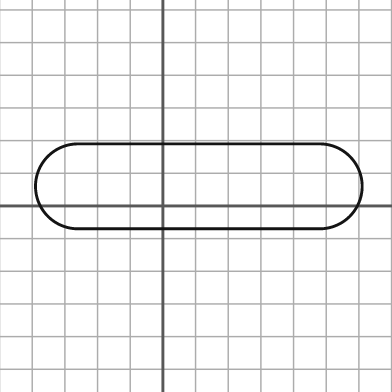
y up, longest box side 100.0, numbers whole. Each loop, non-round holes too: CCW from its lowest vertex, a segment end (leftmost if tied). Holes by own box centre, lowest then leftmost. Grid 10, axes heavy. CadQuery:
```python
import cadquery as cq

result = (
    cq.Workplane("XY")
    .moveTo(-26.0, -7.0)
    .lineTo(48.0, -7.0)
    .threePointArc((61.0, 6.0), (48.0, 19.0))
    .lineTo(-26.0, 19.0)
    .threePointArc((-39.0, 6.0), (-26.0, -7.0))
    .close()
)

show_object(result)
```